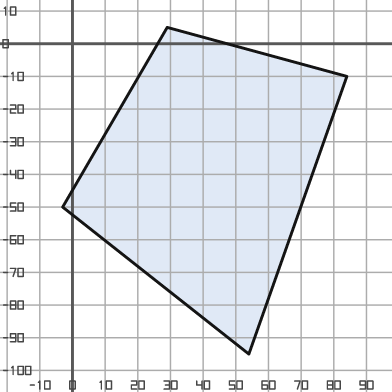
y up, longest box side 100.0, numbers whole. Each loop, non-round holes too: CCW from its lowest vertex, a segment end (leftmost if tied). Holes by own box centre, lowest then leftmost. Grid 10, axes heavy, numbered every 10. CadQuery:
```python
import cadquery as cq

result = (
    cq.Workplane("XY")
    .moveTo(54.0, -95.0)
    .lineTo(84.0, -10.0)
    .lineTo(29.0, 5.0)
    .lineTo(-3.0, -50.0)
    .close()
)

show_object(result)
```